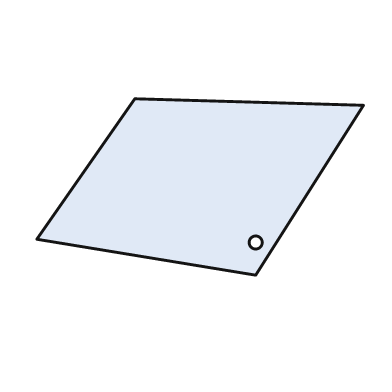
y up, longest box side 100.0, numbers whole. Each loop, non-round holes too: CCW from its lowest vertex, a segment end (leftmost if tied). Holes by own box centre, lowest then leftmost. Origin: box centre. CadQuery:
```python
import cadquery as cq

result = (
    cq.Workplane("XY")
    .moveTo(17.0, -27.0)
    .lineTo(50.0, 25.0)
    .lineTo(-20.0, 27.0)
    .lineTo(-50.0, -16.0)
    .close()
    .moveTo(17.0, -17.0)
    .circle(2.0)
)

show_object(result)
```